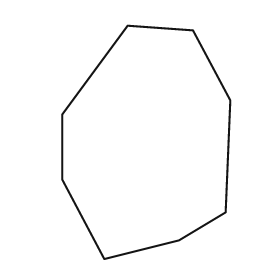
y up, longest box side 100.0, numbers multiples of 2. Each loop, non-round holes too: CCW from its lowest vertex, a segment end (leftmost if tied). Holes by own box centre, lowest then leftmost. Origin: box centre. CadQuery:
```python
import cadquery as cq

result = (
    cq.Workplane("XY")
    .moveTo(-18.0, -50.0)
    .lineTo(14.0, -42.0)
    .lineTo(34.0, -30.0)
    .lineTo(36.0, 18.0)
    .lineTo(20.0, 48.0)
    .lineTo(-8.0, 50.0)
    .lineTo(-36.0, 12.0)
    .lineTo(-36.0, -16.0)
    .close()
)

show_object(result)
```